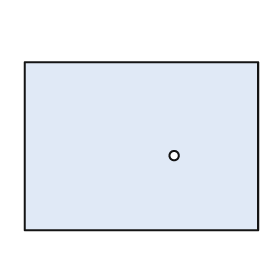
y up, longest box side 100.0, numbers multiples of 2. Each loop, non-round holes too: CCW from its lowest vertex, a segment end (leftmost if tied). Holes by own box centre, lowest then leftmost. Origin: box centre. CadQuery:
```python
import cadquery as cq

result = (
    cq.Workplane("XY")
    .moveTo(-50.0, -36.0)
    .lineTo(50.0, -36.0)
    .lineTo(50.0, 36.0)
    .lineTo(-50.0, 36.0)
    .close()
    .moveTo(14.0, -4.0)
    .circle(2.0)
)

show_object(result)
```